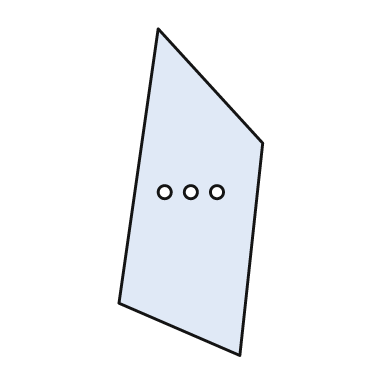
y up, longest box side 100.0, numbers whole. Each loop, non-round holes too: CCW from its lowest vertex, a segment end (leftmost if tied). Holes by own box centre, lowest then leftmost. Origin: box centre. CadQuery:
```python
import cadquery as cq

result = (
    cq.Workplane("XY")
    .moveTo(15.0, -50.0)
    .lineTo(22.0, 15.0)
    .lineTo(-10.0, 50.0)
    .lineTo(-22.0, -34.0)
    .close()
    .moveTo(-8.0, 0.0)
    .circle(2.0)
    .moveTo(0.0, 0.0)
    .circle(2.0)
    .moveTo(8.0, 0.0)
    .circle(2.0)
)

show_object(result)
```